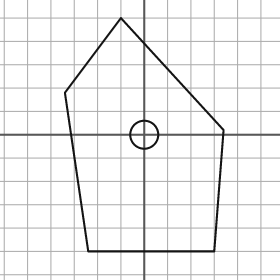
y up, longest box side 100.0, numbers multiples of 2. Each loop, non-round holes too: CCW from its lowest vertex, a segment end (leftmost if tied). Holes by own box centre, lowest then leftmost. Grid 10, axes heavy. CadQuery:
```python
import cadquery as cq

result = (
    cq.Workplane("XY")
    .moveTo(-24.0, -50.0)
    .lineTo(30.0, -50.0)
    .lineTo(34.0, 2.0)
    .lineTo(-10.0, 50.0)
    .lineTo(-34.0, 18.0)
    .close()
    .moveTo(0.0, 0.0)
    .circle(6.0)
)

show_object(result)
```